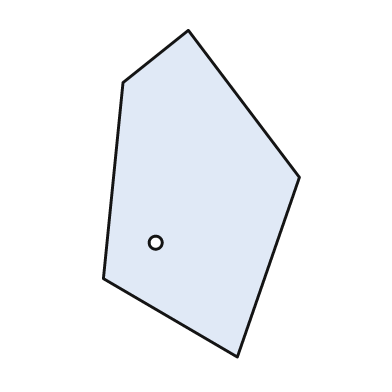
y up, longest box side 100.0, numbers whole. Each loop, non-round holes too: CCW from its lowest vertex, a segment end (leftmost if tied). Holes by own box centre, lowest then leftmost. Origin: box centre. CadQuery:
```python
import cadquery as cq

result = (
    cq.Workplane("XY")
    .moveTo(11.0, -50.0)
    .lineTo(30.0, 5.0)
    .lineTo(-4.0, 50.0)
    .lineTo(-24.0, 34.0)
    .lineTo(-30.0, -26.0)
    .close()
    .moveTo(-14.0, -15.0)
    .circle(2.0)
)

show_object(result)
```